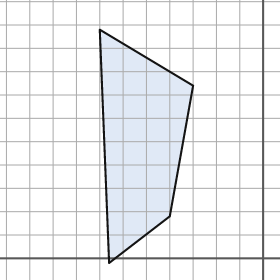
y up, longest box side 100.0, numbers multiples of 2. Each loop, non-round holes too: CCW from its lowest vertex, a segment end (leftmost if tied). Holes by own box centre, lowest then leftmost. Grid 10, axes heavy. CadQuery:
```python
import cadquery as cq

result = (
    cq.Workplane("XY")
    .moveTo(-66.0, -2.0)
    .lineTo(-40.0, 18.0)
    .lineTo(-30.0, 74.0)
    .lineTo(-70.0, 98.0)
    .close()
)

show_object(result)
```